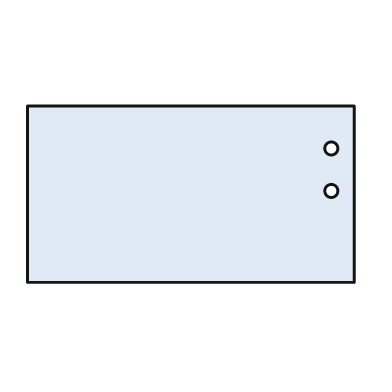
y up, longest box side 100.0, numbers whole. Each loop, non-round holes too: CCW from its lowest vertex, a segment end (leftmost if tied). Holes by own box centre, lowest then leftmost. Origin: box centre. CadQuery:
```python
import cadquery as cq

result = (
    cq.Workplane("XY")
    .moveTo(-50.0, -27.0)
    .lineTo(50.0, -27.0)
    .lineTo(50.0, 27.0)
    .lineTo(-50.0, 27.0)
    .close()
    .moveTo(43.0, 1.0)
    .circle(2.0)
    .moveTo(43.0, 14.0)
    .circle(2.0)
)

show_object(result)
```